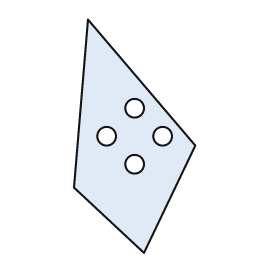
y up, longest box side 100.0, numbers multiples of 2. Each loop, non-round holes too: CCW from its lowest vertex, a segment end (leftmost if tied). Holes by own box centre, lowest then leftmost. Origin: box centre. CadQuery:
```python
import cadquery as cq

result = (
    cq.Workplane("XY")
    .moveTo(4.0, -50.0)
    .lineTo(26.0, -4.0)
    .lineTo(-20.0, 50.0)
    .lineTo(-26.0, -22.0)
    .close()
    .moveTo(0.0, -12.0)
    .circle(4.0)
    .moveTo(-12.0, 0.0)
    .circle(4.0)
    .moveTo(12.0, 0.0)
    .circle(4.0)
    .moveTo(0.0, 12.0)
    .circle(4.0)
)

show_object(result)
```